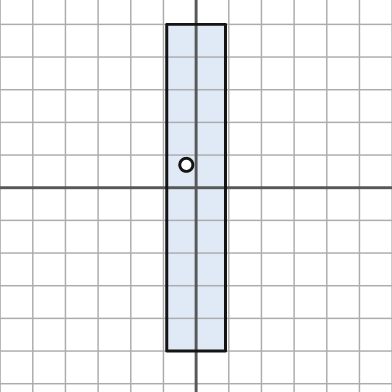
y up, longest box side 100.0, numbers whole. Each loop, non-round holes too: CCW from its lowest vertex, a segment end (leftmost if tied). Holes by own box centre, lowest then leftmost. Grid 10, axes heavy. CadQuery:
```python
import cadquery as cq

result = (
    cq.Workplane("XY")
    .moveTo(-9.0, -50.0)
    .lineTo(9.0, -50.0)
    .lineTo(9.0, 50.0)
    .lineTo(-9.0, 50.0)
    .close()
    .moveTo(-3.0, 7.0)
    .circle(2.0)
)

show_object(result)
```